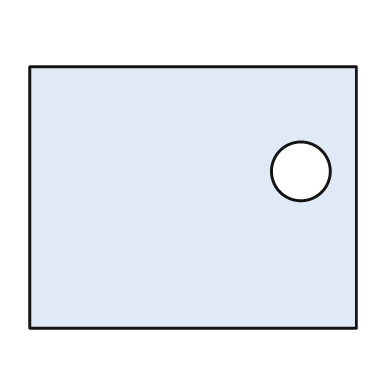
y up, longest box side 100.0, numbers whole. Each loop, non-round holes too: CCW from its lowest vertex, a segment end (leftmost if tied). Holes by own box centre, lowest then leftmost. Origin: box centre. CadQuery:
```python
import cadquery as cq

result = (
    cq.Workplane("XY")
    .moveTo(-50.0, -40.0)
    .lineTo(50.0, -40.0)
    .lineTo(50.0, 40.0)
    .lineTo(-50.0, 40.0)
    .close()
    .moveTo(33.0, 8.0)
    .circle(9.0)
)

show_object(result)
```